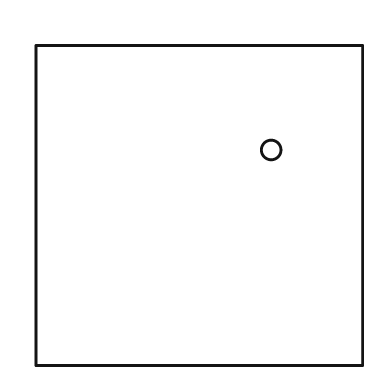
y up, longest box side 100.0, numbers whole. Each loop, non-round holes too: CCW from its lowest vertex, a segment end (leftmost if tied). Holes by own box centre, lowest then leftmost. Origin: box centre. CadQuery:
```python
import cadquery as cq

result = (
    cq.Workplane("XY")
    .moveTo(-50.0, -49.0)
    .lineTo(50.0, -49.0)
    .lineTo(50.0, 49.0)
    .lineTo(-50.0, 49.0)
    .close()
    .moveTo(22.0, 17.0)
    .circle(3.0)
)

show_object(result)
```